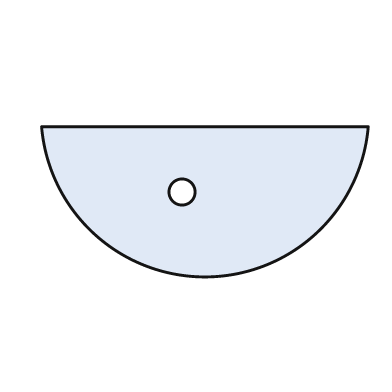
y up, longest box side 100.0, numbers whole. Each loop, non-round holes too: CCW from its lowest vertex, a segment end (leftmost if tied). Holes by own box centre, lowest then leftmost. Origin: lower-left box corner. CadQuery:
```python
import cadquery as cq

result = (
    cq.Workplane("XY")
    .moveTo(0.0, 46.0)
    .threePointArc((50.0, 0.0), (100.0, 46.0))
    .close()
    .moveTo(43.0, 26.0)
    .circle(4.0)
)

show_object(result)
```